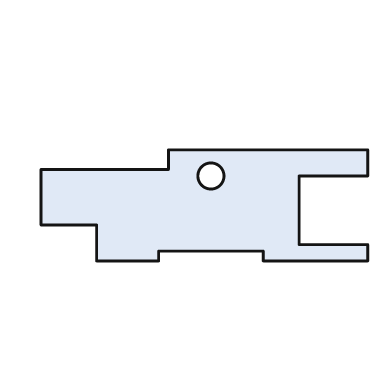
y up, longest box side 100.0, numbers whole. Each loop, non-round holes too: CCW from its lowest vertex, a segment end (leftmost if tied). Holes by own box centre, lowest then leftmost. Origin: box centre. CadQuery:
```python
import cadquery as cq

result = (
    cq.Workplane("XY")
    .moveTo(-33.0, -17.0)
    .lineTo(-14.0, -17.0)
    .lineTo(-14.0, -14.0)
    .lineTo(18.0, -14.0)
    .lineTo(18.0, -17.0)
    .lineTo(50.0, -17.0)
    .lineTo(50.0, -12.0)
    .lineTo(29.0, -12.0)
    .lineTo(29.0, 9.0)
    .lineTo(50.0, 9.0)
    .lineTo(50.0, 17.0)
    .lineTo(-11.0, 17.0)
    .lineTo(-11.0, 11.0)
    .lineTo(-50.0, 11.0)
    .lineTo(-50.0, -6.0)
    .lineTo(-33.0, -6.0)
    .close()
    .moveTo(2.0, 9.0)
    .circle(4.0)
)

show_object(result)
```